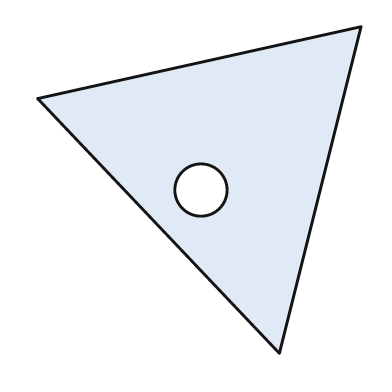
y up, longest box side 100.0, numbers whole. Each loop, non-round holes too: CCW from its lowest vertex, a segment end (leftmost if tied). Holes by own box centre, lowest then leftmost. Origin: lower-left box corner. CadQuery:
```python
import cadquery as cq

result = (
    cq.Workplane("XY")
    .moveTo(74.0, 0.0)
    .lineTo(99.0, 100.0)
    .lineTo(0.0, 78.0)
    .close()
    .moveTo(50.0, 50.0)
    .circle(8.0)
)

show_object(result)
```